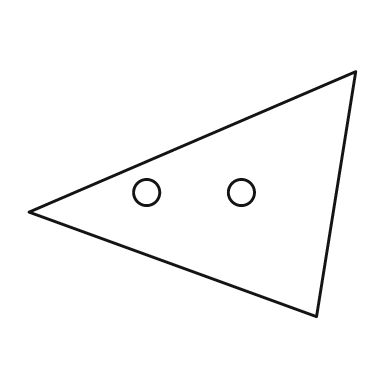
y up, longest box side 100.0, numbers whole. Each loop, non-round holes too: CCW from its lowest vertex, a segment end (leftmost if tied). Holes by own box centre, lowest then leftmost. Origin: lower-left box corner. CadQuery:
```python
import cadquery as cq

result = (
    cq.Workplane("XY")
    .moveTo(88.0, 0.0)
    .lineTo(100.0, 75.0)
    .lineTo(0.0, 32.0)
    .close()
    .moveTo(36.0, 38.0)
    .circle(4.0)
    .moveTo(65.0, 38.0)
    .circle(4.0)
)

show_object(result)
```